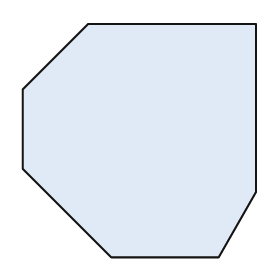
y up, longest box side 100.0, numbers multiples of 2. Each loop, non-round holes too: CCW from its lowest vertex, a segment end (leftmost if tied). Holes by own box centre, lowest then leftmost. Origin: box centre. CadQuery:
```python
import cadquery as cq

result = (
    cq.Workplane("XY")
    .moveTo(-12.0, -50.0)
    .lineTo(34.0, -50.0)
    .lineTo(50.0, -22.0)
    .lineTo(50.0, 50.0)
    .lineTo(-22.0, 50.0)
    .lineTo(-50.0, 22.0)
    .lineTo(-50.0, -12.0)
    .close()
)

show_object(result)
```